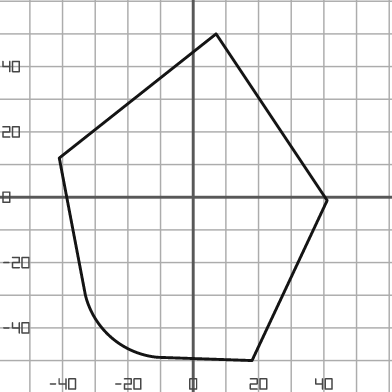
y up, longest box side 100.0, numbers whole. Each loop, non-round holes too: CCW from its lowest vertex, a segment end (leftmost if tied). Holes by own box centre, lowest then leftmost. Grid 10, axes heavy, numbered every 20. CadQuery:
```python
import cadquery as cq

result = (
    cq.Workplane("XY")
    .moveTo(18.0, -50.0)
    .lineTo(41.0, -1.0)
    .lineTo(7.0, 50.0)
    .lineTo(-41.0, 12.0)
    .lineTo(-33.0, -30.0)
    .threePointArc((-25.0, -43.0), (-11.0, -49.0))
    .close()
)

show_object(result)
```